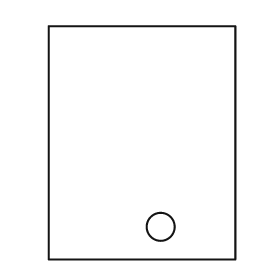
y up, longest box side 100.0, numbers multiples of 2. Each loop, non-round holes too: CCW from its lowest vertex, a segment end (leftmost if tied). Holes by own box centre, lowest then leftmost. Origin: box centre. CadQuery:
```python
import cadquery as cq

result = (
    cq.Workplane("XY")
    .moveTo(-40.0, -50.0)
    .lineTo(40.0, -50.0)
    .lineTo(40.0, 50.0)
    .lineTo(-40.0, 50.0)
    .close()
    .moveTo(8.0, -36.0)
    .circle(6.0)
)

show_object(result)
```